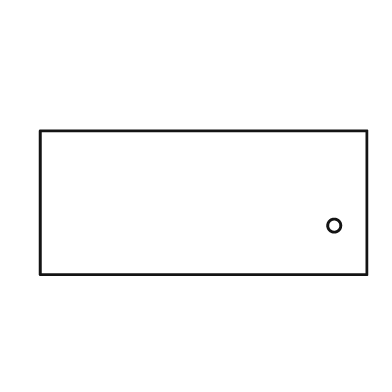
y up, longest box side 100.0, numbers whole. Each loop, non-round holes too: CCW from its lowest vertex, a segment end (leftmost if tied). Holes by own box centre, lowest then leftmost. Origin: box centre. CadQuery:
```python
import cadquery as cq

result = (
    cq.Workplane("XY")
    .moveTo(-50.0, -22.0)
    .lineTo(50.0, -22.0)
    .lineTo(50.0, 22.0)
    .lineTo(-50.0, 22.0)
    .close()
    .moveTo(40.0, -7.0)
    .circle(2.0)
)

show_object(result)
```